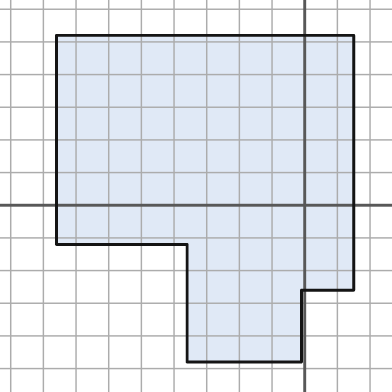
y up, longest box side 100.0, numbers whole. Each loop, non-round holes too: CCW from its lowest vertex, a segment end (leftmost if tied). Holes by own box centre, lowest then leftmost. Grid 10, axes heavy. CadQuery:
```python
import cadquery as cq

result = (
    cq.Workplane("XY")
    .moveTo(-36.0, -48.0)
    .lineTo(-1.0, -48.0)
    .lineTo(-1.0, -26.0)
    .lineTo(15.0, -26.0)
    .lineTo(15.0, 52.0)
    .lineTo(-76.0, 52.0)
    .lineTo(-76.0, -12.0)
    .lineTo(-36.0, -12.0)
    .close()
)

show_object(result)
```